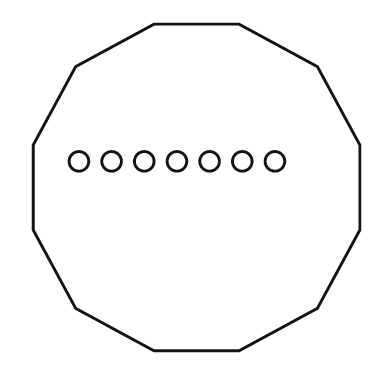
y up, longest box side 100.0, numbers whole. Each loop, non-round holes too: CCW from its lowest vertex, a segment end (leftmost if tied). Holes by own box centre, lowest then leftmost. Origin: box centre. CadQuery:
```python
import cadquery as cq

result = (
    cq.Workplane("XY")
    .moveTo(-13.0, -50.0)
    .lineTo(13.0, -50.0)
    .lineTo(37.0, -37.0)
    .lineTo(50.0, -13.0)
    .lineTo(50.0, 13.0)
    .lineTo(37.0, 37.0)
    .lineTo(13.0, 50.0)
    .lineTo(-13.0, 50.0)
    .lineTo(-37.0, 37.0)
    .lineTo(-50.0, 13.0)
    .lineTo(-50.0, -13.0)
    .lineTo(-37.0, -37.0)
    .close()
    .moveTo(-36.0, 8.0)
    .circle(3.0)
    .moveTo(-26.0, 8.0)
    .circle(3.0)
    .moveTo(-16.0, 8.0)
    .circle(3.0)
    .moveTo(-6.0, 8.0)
    .circle(3.0)
    .moveTo(4.0, 8.0)
    .circle(3.0)
    .moveTo(14.0, 8.0)
    .circle(3.0)
    .moveTo(24.0, 8.0)
    .circle(3.0)
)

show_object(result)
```